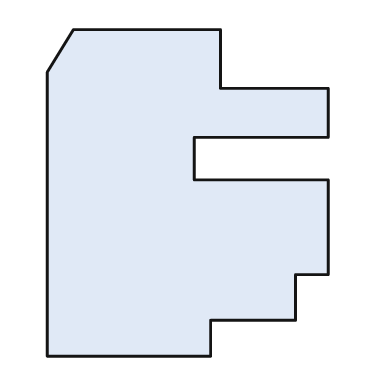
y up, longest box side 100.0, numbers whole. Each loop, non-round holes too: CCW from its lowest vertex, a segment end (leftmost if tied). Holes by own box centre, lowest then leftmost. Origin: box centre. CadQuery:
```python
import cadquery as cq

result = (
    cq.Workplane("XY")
    .moveTo(-43.0, -50.0)
    .lineTo(7.0, -50.0)
    .lineTo(7.0, -39.0)
    .lineTo(33.0, -39.0)
    .lineTo(33.0, -25.0)
    .lineTo(43.0, -25.0)
    .lineTo(43.0, 4.0)
    .lineTo(2.0, 4.0)
    .lineTo(2.0, 17.0)
    .lineTo(43.0, 17.0)
    .lineTo(43.0, 32.0)
    .lineTo(10.0, 32.0)
    .lineTo(10.0, 50.0)
    .lineTo(-35.0, 50.0)
    .lineTo(-43.0, 37.0)
    .close()
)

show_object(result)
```